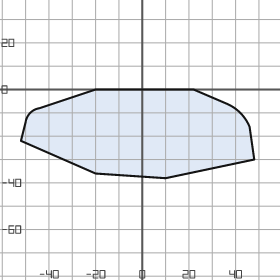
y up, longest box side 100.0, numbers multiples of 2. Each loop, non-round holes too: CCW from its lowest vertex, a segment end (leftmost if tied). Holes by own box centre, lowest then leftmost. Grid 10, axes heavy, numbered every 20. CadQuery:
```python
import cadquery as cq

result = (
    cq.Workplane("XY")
    .moveTo(10.0, -38.0)
    .lineTo(48.0, -30.0)
    .lineTo(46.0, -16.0)
    .threePointArc((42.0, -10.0), (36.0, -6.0))
    .lineTo(22.0, 0.0)
    .lineTo(-20.0, 0.0)
    .lineTo(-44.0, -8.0)
    .threePointArc((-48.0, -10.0), (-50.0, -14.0))
    .lineTo(-52.0, -22.0)
    .lineTo(-20.0, -36.0)
    .close()
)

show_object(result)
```